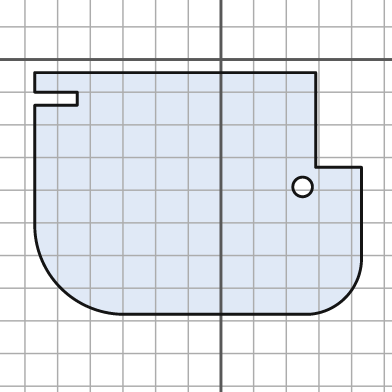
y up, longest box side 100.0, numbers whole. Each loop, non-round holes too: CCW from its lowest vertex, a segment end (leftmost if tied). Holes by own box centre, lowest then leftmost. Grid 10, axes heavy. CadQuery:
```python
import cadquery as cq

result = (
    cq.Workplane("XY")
    .moveTo(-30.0, -78.0)
    .lineTo(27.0, -78.0)
    .threePointArc((38.0, -73.0), (43.0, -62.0))
    .lineTo(43.0, -33.0)
    .lineTo(29.0, -33.0)
    .lineTo(29.0, -4.0)
    .lineTo(-57.0, -4.0)
    .lineTo(-57.0, -10.0)
    .lineTo(-44.0, -10.0)
    .lineTo(-44.0, -14.0)
    .lineTo(-57.0, -14.0)
    .lineTo(-57.0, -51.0)
    .threePointArc((-49.0, -70.0), (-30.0, -78.0))
    .close()
    .moveTo(25.0, -39.0)
    .circle(3.0)
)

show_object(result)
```